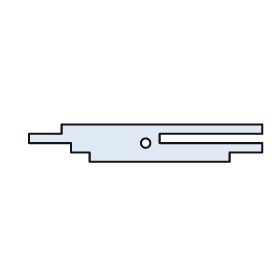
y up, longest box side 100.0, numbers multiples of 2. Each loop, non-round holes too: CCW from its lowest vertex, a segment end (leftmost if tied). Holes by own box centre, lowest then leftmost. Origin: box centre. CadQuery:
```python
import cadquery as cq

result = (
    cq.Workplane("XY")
    .moveTo(-24.0, -8.0)
    .lineTo(36.0, -8.0)
    .lineTo(36.0, -4.0)
    .lineTo(50.0, -4.0)
    .lineTo(50.0, 0.0)
    .lineTo(6.0, 0.0)
    .lineTo(6.0, 4.0)
    .lineTo(50.0, 4.0)
    .lineTo(50.0, 8.0)
    .lineTo(-36.0, 8.0)
    .lineTo(-36.0, 4.0)
    .lineTo(-50.0, 4.0)
    .lineTo(-50.0, 0.0)
    .lineTo(-32.0, 0.0)
    .lineTo(-32.0, -4.0)
    .lineTo(-24.0, -4.0)
    .close()
    .moveTo(0.0, 0.0)
    .circle(2.0)
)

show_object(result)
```